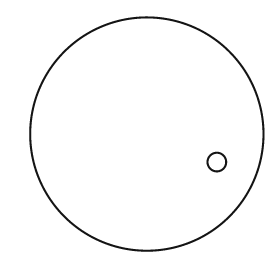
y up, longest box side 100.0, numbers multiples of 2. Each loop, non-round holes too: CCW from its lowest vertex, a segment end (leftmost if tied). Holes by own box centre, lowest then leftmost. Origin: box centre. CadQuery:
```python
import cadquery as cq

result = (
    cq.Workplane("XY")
    .moveTo(0.0, 0.0)
    .circle(50.0)
    .moveTo(30.0, -12.0)
    .circle(4.0)
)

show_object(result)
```